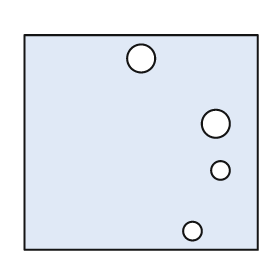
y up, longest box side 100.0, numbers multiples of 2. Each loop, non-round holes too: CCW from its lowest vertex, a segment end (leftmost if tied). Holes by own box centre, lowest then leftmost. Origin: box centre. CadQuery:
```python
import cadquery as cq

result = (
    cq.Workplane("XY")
    .moveTo(-50.0, -46.0)
    .lineTo(50.0, -46.0)
    .lineTo(50.0, 46.0)
    .lineTo(-50.0, 46.0)
    .close()
    .moveTo(22.0, -38.0)
    .circle(4.0)
    .moveTo(34.0, -12.0)
    .circle(4.0)
    .moveTo(32.0, 8.0)
    .circle(6.0)
    .moveTo(0.0, 36.0)
    .circle(6.0)
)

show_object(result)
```